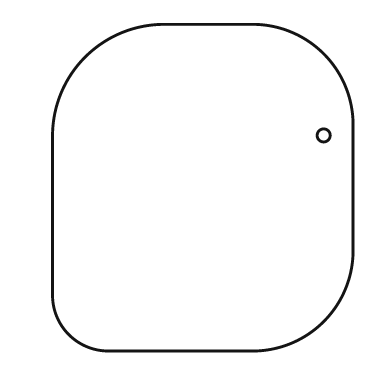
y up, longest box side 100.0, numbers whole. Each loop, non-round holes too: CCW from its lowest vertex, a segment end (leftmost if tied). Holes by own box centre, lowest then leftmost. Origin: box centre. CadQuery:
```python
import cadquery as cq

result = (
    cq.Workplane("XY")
    .moveTo(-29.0, -50.0)
    .lineTo(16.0, -50.0)
    .threePointArc((37.0, -41.0), (46.0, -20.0))
    .lineTo(46.0, 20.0)
    .threePointArc((37.0, 41.0), (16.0, 50.0))
    .lineTo(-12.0, 50.0)
    .threePointArc((-36.0, 40.0), (-46.0, 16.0))
    .lineTo(-46.0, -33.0)
    .threePointArc((-41.0, -45.0), (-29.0, -50.0))
    .close()
    .moveTo(37.0, 16.0)
    .circle(2.0)
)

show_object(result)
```